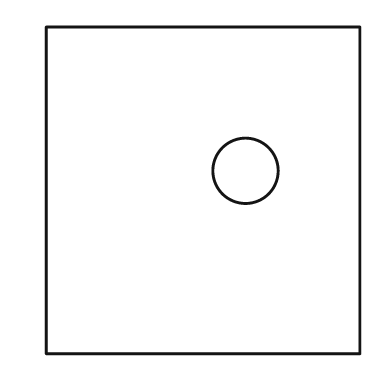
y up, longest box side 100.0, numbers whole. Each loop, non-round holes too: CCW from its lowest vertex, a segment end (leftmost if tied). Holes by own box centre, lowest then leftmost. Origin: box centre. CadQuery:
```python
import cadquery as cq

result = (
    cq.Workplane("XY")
    .moveTo(-48.0, -50.0)
    .lineTo(48.0, -50.0)
    .lineTo(48.0, 50.0)
    .lineTo(-48.0, 50.0)
    .close()
    .moveTo(13.0, 6.0)
    .circle(10.0)
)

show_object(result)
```